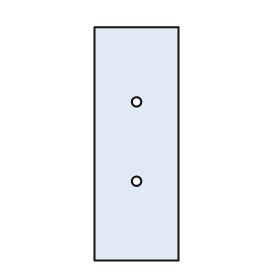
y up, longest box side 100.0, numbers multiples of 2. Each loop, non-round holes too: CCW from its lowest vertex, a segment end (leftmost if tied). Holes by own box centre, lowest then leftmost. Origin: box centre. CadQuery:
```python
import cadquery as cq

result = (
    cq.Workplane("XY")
    .moveTo(-18.0, -50.0)
    .lineTo(18.0, -50.0)
    .lineTo(18.0, 50.0)
    .lineTo(-18.0, 50.0)
    .close()
    .moveTo(0.0, -16.0)
    .circle(2.0)
    .moveTo(0.0, 18.0)
    .circle(2.0)
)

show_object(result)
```